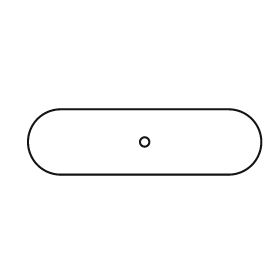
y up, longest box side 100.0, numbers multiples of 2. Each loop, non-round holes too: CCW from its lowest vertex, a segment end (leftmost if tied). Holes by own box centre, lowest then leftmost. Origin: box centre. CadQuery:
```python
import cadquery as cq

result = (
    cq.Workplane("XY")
    .moveTo(-36.0, -14.0)
    .lineTo(36.0, -14.0)
    .threePointArc((50.0, 0.0), (36.0, 14.0))
    .lineTo(-36.0, 14.0)
    .threePointArc((-50.0, 0.0), (-36.0, -14.0))
    .close()
    .moveTo(0.0, 0.0)
    .circle(2.0)
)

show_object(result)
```